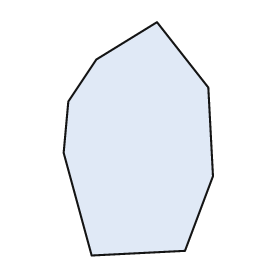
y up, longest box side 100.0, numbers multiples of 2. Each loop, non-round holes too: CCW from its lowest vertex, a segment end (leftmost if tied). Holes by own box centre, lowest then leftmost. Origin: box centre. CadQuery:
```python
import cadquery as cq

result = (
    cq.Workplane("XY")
    .moveTo(-20.0, -50.0)
    .lineTo(20.0, -48.0)
    .lineTo(32.0, -16.0)
    .lineTo(30.0, 22.0)
    .lineTo(8.0, 50.0)
    .lineTo(-18.0, 34.0)
    .lineTo(-30.0, 16.0)
    .lineTo(-32.0, -6.0)
    .close()
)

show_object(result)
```